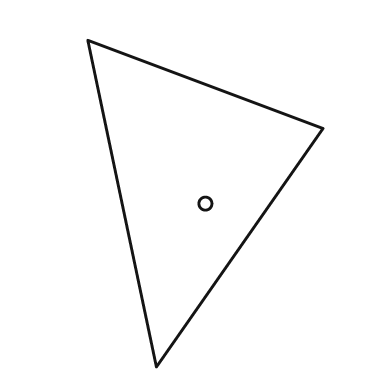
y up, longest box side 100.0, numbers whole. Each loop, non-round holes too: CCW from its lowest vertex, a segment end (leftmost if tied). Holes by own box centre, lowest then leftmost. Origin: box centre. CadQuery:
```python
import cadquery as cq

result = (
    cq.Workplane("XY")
    .moveTo(-15.0, -50.0)
    .lineTo(36.0, 23.0)
    .lineTo(-36.0, 50.0)
    .close()
    .moveTo(0.0, 0.0)
    .circle(2.0)
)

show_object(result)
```